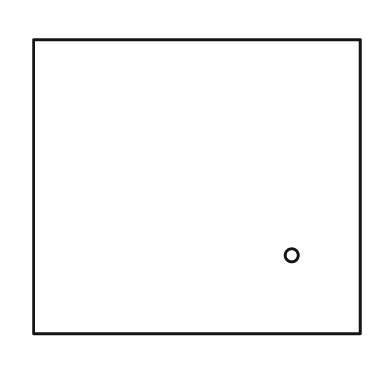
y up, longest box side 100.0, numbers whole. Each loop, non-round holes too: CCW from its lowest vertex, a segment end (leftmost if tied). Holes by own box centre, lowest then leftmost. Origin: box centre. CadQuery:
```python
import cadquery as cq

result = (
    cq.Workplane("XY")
    .moveTo(-50.0, -45.0)
    .lineTo(50.0, -45.0)
    .lineTo(50.0, 45.0)
    .lineTo(-50.0, 45.0)
    .close()
    .moveTo(29.0, -21.0)
    .circle(2.0)
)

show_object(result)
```